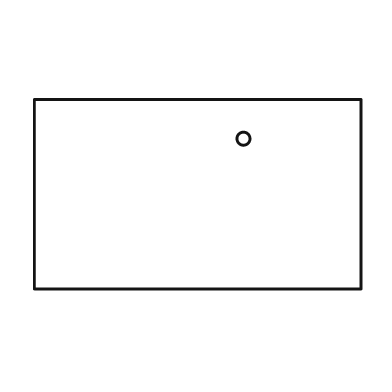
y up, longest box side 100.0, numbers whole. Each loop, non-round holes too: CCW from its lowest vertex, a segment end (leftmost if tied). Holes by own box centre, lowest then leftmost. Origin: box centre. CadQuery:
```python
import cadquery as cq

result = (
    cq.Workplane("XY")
    .moveTo(-50.0, -29.0)
    .lineTo(50.0, -29.0)
    .lineTo(50.0, 29.0)
    .lineTo(-50.0, 29.0)
    .close()
    .moveTo(14.0, 17.0)
    .circle(2.0)
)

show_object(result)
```